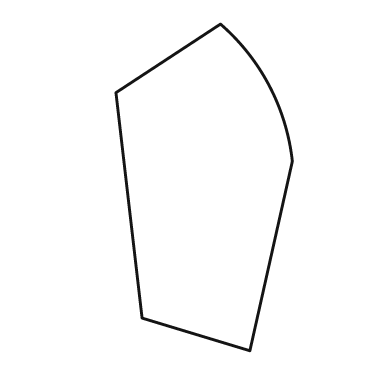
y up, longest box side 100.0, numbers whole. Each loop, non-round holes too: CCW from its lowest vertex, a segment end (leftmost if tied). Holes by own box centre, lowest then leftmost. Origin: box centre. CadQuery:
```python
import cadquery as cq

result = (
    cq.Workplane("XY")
    .moveTo(14.0, -50.0)
    .lineTo(27.0, 8.0)
    .threePointArc((20.0, 31.0), (5.0, 50.0))
    .lineTo(-27.0, 29.0)
    .lineTo(-19.0, -40.0)
    .close()
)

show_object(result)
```